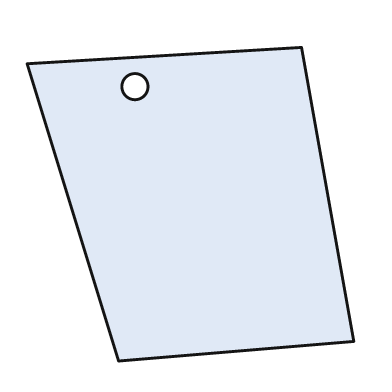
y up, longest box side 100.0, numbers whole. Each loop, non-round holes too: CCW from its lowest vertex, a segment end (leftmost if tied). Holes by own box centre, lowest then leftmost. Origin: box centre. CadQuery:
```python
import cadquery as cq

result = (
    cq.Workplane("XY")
    .moveTo(-22.0, -48.0)
    .lineTo(50.0, -42.0)
    .lineTo(34.0, 48.0)
    .lineTo(-50.0, 43.0)
    .close()
    .moveTo(-17.0, 36.0)
    .circle(4.0)
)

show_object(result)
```